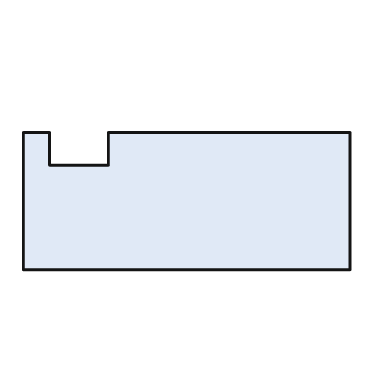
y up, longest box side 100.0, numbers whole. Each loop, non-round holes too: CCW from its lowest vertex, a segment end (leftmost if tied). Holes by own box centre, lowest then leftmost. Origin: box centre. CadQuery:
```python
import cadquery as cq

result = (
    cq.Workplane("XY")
    .moveTo(-50.0, -21.0)
    .lineTo(50.0, -21.0)
    .lineTo(50.0, 21.0)
    .lineTo(-24.0, 21.0)
    .lineTo(-24.0, 11.0)
    .lineTo(-42.0, 11.0)
    .lineTo(-42.0, 21.0)
    .lineTo(-50.0, 21.0)
    .close()
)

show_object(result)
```